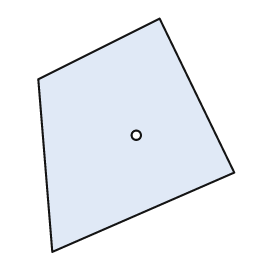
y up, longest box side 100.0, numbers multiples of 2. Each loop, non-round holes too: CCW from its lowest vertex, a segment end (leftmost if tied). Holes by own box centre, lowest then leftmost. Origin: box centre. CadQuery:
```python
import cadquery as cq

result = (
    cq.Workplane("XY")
    .moveTo(-36.0, -50.0)
    .lineTo(42.0, -16.0)
    .lineTo(10.0, 50.0)
    .lineTo(-42.0, 24.0)
    .close()
    .moveTo(0.0, 0.0)
    .circle(2.0)
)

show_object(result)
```